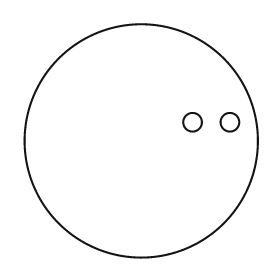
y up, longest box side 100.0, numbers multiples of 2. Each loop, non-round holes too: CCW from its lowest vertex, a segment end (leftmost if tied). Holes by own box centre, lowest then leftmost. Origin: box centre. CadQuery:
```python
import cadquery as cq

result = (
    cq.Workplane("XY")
    .moveTo(0.0, 0.0)
    .circle(50.0)
    .moveTo(22.0, 8.0)
    .circle(4.0)
    .moveTo(38.0, 8.0)
    .circle(4.0)
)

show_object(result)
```